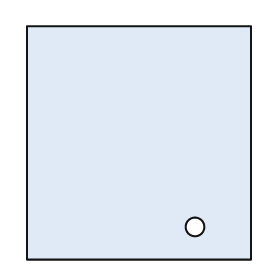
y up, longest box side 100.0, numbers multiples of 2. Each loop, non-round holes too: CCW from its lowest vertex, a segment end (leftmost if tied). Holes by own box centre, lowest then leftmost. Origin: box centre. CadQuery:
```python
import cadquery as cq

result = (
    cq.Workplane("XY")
    .moveTo(-48.0, -50.0)
    .lineTo(48.0, -50.0)
    .lineTo(48.0, 50.0)
    .lineTo(-48.0, 50.0)
    .close()
    .moveTo(24.0, -36.0)
    .circle(4.0)
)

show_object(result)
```